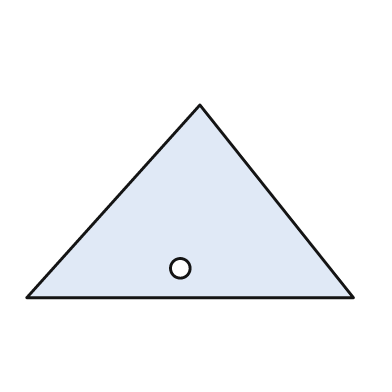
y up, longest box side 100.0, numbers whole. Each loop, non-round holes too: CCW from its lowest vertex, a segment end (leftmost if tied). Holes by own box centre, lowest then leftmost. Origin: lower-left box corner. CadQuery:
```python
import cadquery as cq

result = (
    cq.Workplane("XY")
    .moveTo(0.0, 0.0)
    .lineTo(100.0, 0.0)
    .lineTo(53.0, 59.0)
    .close()
    .moveTo(47.0, 9.0)
    .circle(3.0)
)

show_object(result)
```